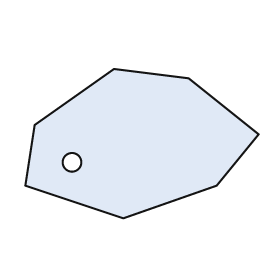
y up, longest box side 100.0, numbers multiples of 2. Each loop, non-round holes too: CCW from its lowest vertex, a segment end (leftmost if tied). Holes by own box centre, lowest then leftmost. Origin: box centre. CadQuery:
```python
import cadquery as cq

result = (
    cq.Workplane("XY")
    .moveTo(-8.0, -32.0)
    .lineTo(32.0, -18.0)
    .lineTo(50.0, 4.0)
    .lineTo(20.0, 28.0)
    .lineTo(-12.0, 32.0)
    .lineTo(-46.0, 8.0)
    .lineTo(-50.0, -18.0)
    .close()
    .moveTo(-30.0, -8.0)
    .circle(4.0)
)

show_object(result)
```